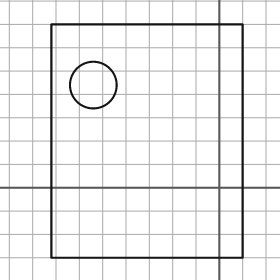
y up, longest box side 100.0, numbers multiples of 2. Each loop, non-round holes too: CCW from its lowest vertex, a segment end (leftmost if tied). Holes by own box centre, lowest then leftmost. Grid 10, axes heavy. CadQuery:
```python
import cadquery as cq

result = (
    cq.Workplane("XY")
    .moveTo(-72.0, -30.0)
    .lineTo(10.0, -30.0)
    .lineTo(10.0, 70.0)
    .lineTo(-72.0, 70.0)
    .close()
    .moveTo(-54.0, 44.0)
    .circle(10.0)
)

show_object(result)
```